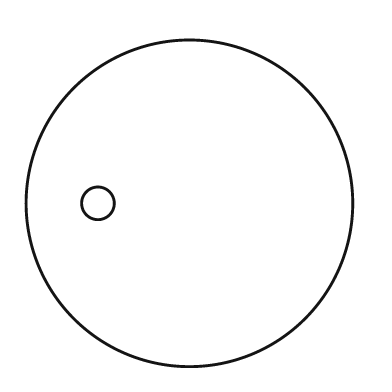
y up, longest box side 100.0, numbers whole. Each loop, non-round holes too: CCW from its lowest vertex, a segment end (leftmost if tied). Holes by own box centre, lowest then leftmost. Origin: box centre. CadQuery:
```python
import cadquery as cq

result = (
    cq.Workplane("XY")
    .moveTo(0.0, 0.0)
    .circle(50.0)
    .moveTo(-28.0, 0.0)
    .circle(5.0)
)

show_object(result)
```